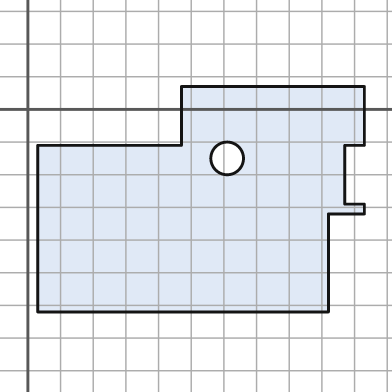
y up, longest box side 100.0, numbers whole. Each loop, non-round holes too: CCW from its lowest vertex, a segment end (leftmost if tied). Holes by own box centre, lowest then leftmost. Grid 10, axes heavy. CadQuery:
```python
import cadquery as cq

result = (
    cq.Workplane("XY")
    .moveTo(3.0, -62.0)
    .lineTo(92.0, -62.0)
    .lineTo(92.0, -32.0)
    .lineTo(103.0, -32.0)
    .lineTo(103.0, -29.0)
    .lineTo(97.0, -29.0)
    .lineTo(97.0, -11.0)
    .lineTo(103.0, -11.0)
    .lineTo(103.0, 7.0)
    .lineTo(47.0, 7.0)
    .lineTo(47.0, -11.0)
    .lineTo(3.0, -11.0)
    .close()
    .moveTo(61.0, -15.0)
    .circle(5.0)
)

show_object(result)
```